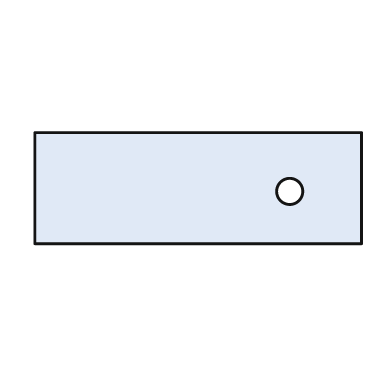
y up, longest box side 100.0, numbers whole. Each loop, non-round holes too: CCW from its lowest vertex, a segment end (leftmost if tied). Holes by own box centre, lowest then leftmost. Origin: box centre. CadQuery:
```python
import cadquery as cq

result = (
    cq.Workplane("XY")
    .moveTo(-50.0, -17.0)
    .lineTo(50.0, -17.0)
    .lineTo(50.0, 17.0)
    .lineTo(-50.0, 17.0)
    .close()
    .moveTo(28.0, -1.0)
    .circle(4.0)
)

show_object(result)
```